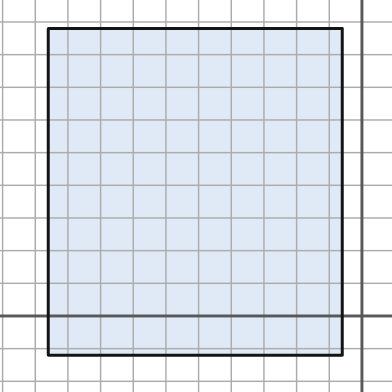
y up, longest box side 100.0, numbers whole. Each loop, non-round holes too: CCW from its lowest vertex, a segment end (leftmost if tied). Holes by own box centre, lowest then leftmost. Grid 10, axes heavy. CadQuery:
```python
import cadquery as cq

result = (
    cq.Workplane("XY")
    .moveTo(-96.0, -12.0)
    .lineTo(-6.0, -12.0)
    .lineTo(-6.0, 88.0)
    .lineTo(-96.0, 88.0)
    .close()
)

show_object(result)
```